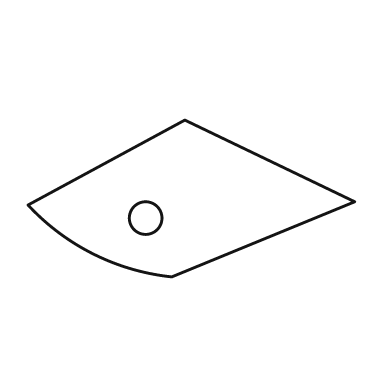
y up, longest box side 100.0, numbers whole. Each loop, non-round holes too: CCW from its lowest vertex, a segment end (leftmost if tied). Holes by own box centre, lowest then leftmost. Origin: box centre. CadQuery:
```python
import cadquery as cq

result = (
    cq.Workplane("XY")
    .moveTo(-6.0, -24.0)
    .lineTo(50.0, -1.0)
    .lineTo(-2.0, 24.0)
    .lineTo(-50.0, -2.0)
    .threePointArc((-30.0, -17.0), (-6.0, -24.0))
    .close()
    .moveTo(-14.0, -6.0)
    .circle(5.0)
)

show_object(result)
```